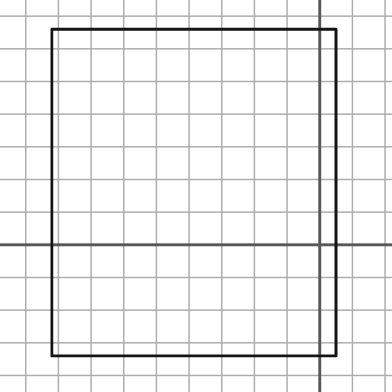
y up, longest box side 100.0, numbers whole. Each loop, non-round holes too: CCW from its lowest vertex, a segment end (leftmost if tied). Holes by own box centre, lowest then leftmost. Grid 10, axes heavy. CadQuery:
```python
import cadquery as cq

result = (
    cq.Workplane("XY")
    .moveTo(-82.0, -34.0)
    .lineTo(5.0, -34.0)
    .lineTo(5.0, 66.0)
    .lineTo(-82.0, 66.0)
    .close()
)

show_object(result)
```